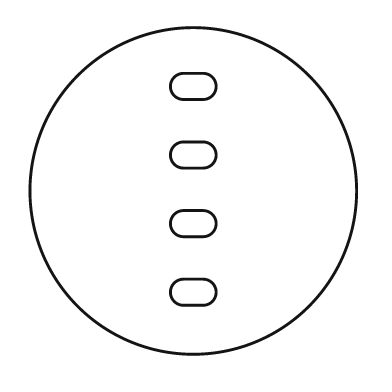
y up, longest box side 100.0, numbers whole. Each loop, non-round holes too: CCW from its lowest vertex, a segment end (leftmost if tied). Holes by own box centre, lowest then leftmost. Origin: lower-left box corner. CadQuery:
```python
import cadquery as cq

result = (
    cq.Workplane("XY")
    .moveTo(50.0, 50.0)
    .circle(50.0)
    .moveTo(47.0, 15.0)
    .lineTo(53.0, 15.0)
    .threePointArc((57.0, 19.0), (53.0, 23.0))
    .lineTo(47.0, 23.0)
    .threePointArc((43.0, 19.0), (47.0, 15.0))
    .close()
    .moveTo(47.0, 36.0)
    .lineTo(53.0, 36.0)
    .threePointArc((57.0, 40.0), (53.0, 44.0))
    .lineTo(47.0, 44.0)
    .threePointArc((43.0, 40.0), (47.0, 36.0))
    .close()
    .moveTo(47.0, 57.0)
    .lineTo(53.0, 57.0)
    .threePointArc((57.0, 61.0), (53.0, 65.0))
    .lineTo(47.0, 65.0)
    .threePointArc((43.0, 61.0), (47.0, 57.0))
    .close()
    .moveTo(47.0, 78.0)
    .lineTo(53.0, 78.0)
    .threePointArc((57.0, 82.0), (53.0, 86.0))
    .lineTo(47.0, 86.0)
    .threePointArc((43.0, 82.0), (47.0, 78.0))
    .close()
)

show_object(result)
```